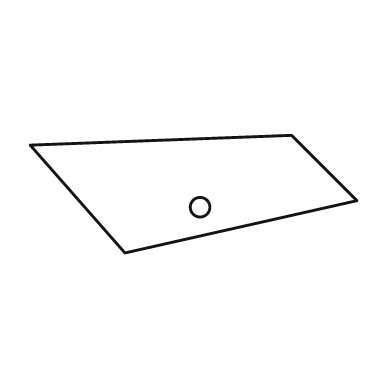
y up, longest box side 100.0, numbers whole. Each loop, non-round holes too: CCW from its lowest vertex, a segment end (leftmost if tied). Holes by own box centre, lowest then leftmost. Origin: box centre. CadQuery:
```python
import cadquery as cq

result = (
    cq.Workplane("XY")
    .moveTo(-21.0, -18.0)
    .lineTo(50.0, -2.0)
    .lineTo(30.0, 18.0)
    .lineTo(-50.0, 15.0)
    .close()
    .moveTo(2.0, -4.0)
    .circle(3.0)
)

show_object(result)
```